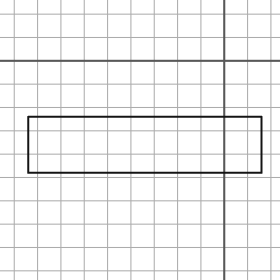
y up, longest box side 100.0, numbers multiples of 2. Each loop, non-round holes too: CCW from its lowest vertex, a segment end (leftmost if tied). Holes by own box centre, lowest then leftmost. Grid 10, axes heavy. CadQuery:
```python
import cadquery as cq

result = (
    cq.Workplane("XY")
    .moveTo(-84.0, -48.0)
    .lineTo(16.0, -48.0)
    .lineTo(16.0, -24.0)
    .lineTo(-84.0, -24.0)
    .close()
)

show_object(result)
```